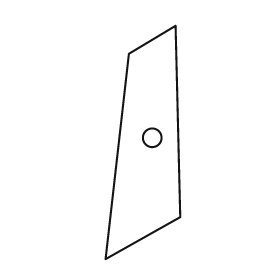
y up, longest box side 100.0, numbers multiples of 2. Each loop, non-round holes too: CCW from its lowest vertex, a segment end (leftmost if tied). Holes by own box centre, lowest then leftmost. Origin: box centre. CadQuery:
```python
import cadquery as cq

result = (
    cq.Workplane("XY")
    .moveTo(-16.0, -50.0)
    .lineTo(16.0, -32.0)
    .lineTo(14.0, 50.0)
    .lineTo(-6.0, 38.0)
    .close()
    .moveTo(4.0, 2.0)
    .circle(4.0)
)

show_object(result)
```